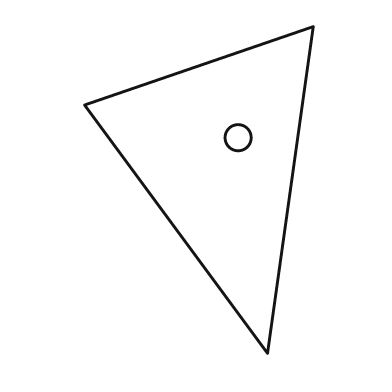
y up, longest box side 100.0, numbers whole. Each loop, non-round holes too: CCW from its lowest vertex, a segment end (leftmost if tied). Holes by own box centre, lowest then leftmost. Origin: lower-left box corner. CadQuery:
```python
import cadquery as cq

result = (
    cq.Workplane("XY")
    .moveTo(56.0, 0.0)
    .lineTo(70.0, 100.0)
    .lineTo(0.0, 76.0)
    .close()
    .moveTo(47.0, 66.0)
    .circle(4.0)
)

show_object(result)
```